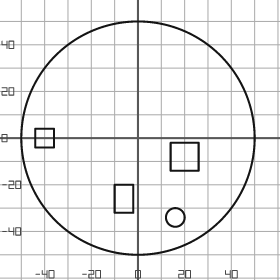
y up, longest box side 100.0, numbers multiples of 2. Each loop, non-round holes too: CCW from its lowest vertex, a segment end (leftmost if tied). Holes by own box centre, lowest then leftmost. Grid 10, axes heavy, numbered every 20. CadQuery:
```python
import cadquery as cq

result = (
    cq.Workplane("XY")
    .moveTo(0.0, 0.0)
    .circle(50.0)
    .moveTo(16.0, -34.0)
    .circle(4.0)
    .moveTo(-10.0, -32.0)
    .lineTo(-2.0, -32.0)
    .lineTo(-2.0, -20.0)
    .lineTo(-10.0, -20.0)
    .close()
    .moveTo(14.0, -14.0)
    .lineTo(26.0, -14.0)
    .lineTo(26.0, -2.0)
    .lineTo(14.0, -2.0)
    .close()
    .moveTo(-44.0, -4.0)
    .lineTo(-36.0, -4.0)
    .lineTo(-36.0, 4.0)
    .lineTo(-44.0, 4.0)
    .close()
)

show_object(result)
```